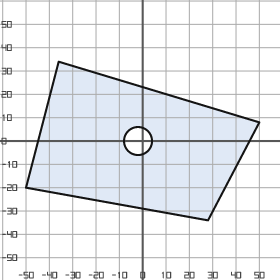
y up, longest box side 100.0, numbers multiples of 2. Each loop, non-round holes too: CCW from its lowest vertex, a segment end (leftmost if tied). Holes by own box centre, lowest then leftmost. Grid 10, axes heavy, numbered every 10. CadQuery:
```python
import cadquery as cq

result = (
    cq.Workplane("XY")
    .moveTo(28.0, -34.0)
    .lineTo(50.0, 8.0)
    .lineTo(-36.0, 34.0)
    .lineTo(-50.0, -20.0)
    .close()
    .moveTo(-2.0, 0.0)
    .circle(6.0)
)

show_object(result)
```